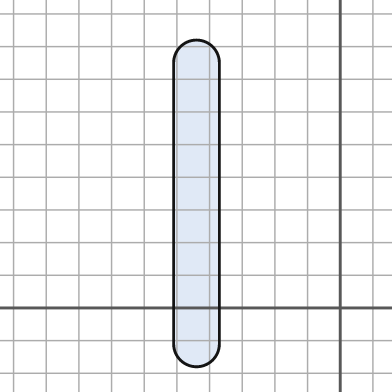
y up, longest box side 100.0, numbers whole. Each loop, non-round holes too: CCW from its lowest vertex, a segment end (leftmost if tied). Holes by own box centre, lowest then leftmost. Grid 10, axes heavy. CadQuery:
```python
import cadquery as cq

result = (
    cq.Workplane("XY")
    .moveTo(-51.0, -11.0)
    .threePointArc((-44.0, -18.0), (-37.0, -11.0))
    .lineTo(-37.0, 75.0)
    .threePointArc((-44.0, 82.0), (-51.0, 75.0))
    .close()
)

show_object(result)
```